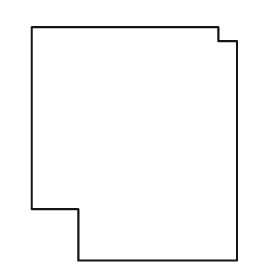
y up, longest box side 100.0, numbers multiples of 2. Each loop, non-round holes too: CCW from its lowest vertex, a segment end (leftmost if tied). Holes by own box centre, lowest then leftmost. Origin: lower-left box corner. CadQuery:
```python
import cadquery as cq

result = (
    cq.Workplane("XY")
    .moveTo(20.0, 0.0)
    .lineTo(88.0, 0.0)
    .lineTo(88.0, 94.0)
    .lineTo(80.0, 94.0)
    .lineTo(80.0, 100.0)
    .lineTo(0.0, 100.0)
    .lineTo(0.0, 22.0)
    .lineTo(20.0, 22.0)
    .close()
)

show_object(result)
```